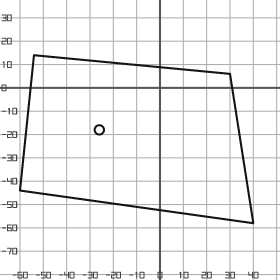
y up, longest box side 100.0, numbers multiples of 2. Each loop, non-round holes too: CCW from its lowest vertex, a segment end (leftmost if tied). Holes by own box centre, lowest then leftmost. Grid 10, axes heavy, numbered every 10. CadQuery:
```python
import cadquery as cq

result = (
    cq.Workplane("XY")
    .moveTo(40.0, -58.0)
    .lineTo(30.0, 6.0)
    .lineTo(-54.0, 14.0)
    .lineTo(-60.0, -44.0)
    .close()
    .moveTo(-26.0, -18.0)
    .circle(2.0)
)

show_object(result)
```